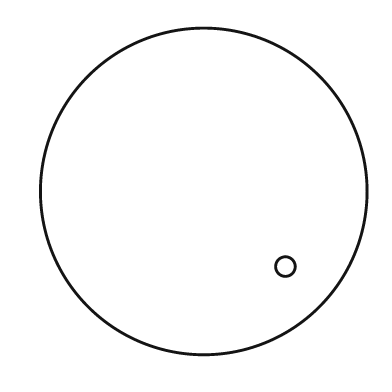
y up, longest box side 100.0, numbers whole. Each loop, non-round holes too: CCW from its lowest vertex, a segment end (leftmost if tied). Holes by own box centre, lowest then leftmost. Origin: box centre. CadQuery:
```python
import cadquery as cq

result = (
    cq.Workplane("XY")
    .moveTo(0.0, 0.0)
    .circle(50.0)
    .moveTo(25.0, -23.0)
    .circle(3.0)
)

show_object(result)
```